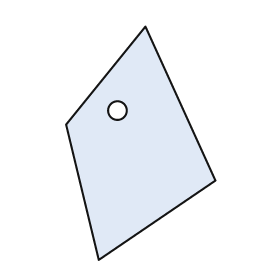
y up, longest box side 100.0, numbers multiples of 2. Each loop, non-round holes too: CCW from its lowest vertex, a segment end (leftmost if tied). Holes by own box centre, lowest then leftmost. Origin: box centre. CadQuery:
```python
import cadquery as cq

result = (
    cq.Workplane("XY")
    .moveTo(-18.0, -50.0)
    .lineTo(32.0, -16.0)
    .lineTo(2.0, 50.0)
    .lineTo(-32.0, 8.0)
    .close()
    .moveTo(-10.0, 14.0)
    .circle(4.0)
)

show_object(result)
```